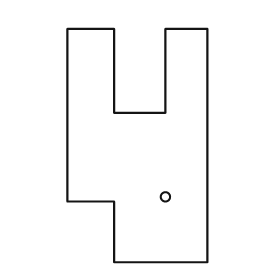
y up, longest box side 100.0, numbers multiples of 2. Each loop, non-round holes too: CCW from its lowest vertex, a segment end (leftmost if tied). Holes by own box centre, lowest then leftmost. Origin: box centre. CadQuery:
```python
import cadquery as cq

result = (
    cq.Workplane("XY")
    .moveTo(-10.0, -50.0)
    .lineTo(30.0, -50.0)
    .lineTo(30.0, 50.0)
    .lineTo(12.0, 50.0)
    .lineTo(12.0, 14.0)
    .lineTo(-10.0, 14.0)
    .lineTo(-10.0, 50.0)
    .lineTo(-30.0, 50.0)
    .lineTo(-30.0, -24.0)
    .lineTo(-10.0, -24.0)
    .close()
    .moveTo(12.0, -22.0)
    .circle(2.0)
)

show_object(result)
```